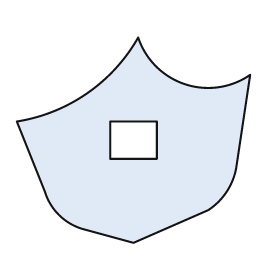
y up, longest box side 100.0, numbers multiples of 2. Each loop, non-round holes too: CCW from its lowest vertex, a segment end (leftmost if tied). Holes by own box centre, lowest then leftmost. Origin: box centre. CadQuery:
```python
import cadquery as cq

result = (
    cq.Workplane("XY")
    .moveTo(0.0, -44.0)
    .lineTo(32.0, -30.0)
    .threePointArc((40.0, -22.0), (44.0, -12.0))
    .lineTo(50.0, 28.0)
    .threePointArc((22.0, 24.0), (2.0, 44.0))
    .threePointArc((-20.0, 20.0), (-50.0, 8.0))
    .lineTo(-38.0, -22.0)
    .threePointArc((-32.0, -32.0), (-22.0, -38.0))
    .close()
    .moveTo(-10.0, -8.0)
    .lineTo(10.0, -8.0)
    .lineTo(10.0, 8.0)
    .lineTo(-10.0, 8.0)
    .close()
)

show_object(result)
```